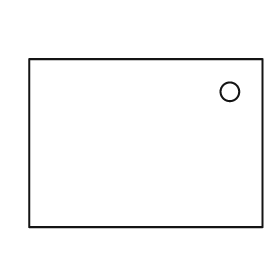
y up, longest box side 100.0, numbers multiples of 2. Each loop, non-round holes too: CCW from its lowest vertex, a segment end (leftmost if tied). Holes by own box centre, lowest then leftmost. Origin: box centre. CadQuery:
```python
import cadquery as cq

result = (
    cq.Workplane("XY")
    .moveTo(-50.0, -36.0)
    .lineTo(50.0, -36.0)
    .lineTo(50.0, 36.0)
    .lineTo(-50.0, 36.0)
    .close()
    .moveTo(36.0, 22.0)
    .circle(4.0)
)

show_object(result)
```